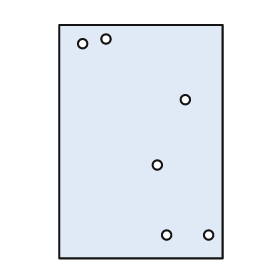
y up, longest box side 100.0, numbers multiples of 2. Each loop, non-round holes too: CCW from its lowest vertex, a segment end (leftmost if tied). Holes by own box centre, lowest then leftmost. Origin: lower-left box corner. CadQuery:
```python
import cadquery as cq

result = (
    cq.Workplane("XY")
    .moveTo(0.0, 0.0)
    .lineTo(70.0, 0.0)
    .lineTo(70.0, 100.0)
    .lineTo(0.0, 100.0)
    .close()
    .moveTo(46.0, 10.0)
    .circle(2.0)
    .moveTo(64.0, 10.0)
    .circle(2.0)
    .moveTo(42.0, 40.0)
    .circle(2.0)
    .moveTo(54.0, 68.0)
    .circle(2.0)
    .moveTo(10.0, 92.0)
    .circle(2.0)
    .moveTo(20.0, 94.0)
    .circle(2.0)
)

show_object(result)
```